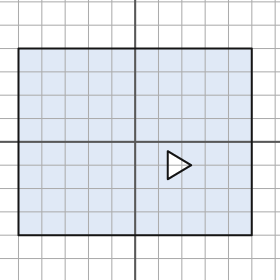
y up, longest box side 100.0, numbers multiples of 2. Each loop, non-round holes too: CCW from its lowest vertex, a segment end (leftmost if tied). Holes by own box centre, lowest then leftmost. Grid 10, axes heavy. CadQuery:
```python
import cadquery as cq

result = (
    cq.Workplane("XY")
    .moveTo(-50.0, -40.0)
    .lineTo(50.0, -40.0)
    .lineTo(50.0, 40.0)
    .lineTo(-50.0, 40.0)
    .close()
    .moveTo(14.0, -16.0)
    .lineTo(24.0, -10.0)
    .lineTo(14.0, -4.0)
    .close()
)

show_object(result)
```